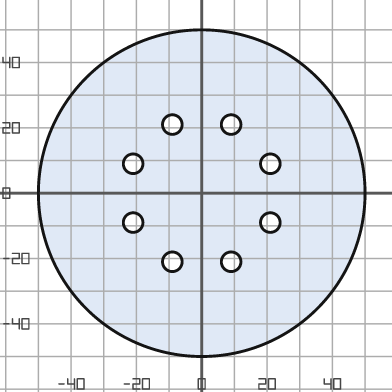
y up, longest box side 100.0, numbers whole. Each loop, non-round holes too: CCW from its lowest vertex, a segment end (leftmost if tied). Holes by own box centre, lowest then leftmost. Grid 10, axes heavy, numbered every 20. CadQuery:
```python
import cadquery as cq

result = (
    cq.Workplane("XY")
    .moveTo(0.0, 0.0)
    .circle(50.0)
    .moveTo(-9.0, -21.0)
    .circle(3.0)
    .moveTo(9.0, -21.0)
    .circle(3.0)
    .moveTo(-21.0, -9.0)
    .circle(3.0)
    .moveTo(21.0, -9.0)
    .circle(3.0)
    .moveTo(-21.0, 9.0)
    .circle(3.0)
    .moveTo(21.0, 9.0)
    .circle(3.0)
    .moveTo(-9.0, 21.0)
    .circle(3.0)
    .moveTo(9.0, 21.0)
    .circle(3.0)
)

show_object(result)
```